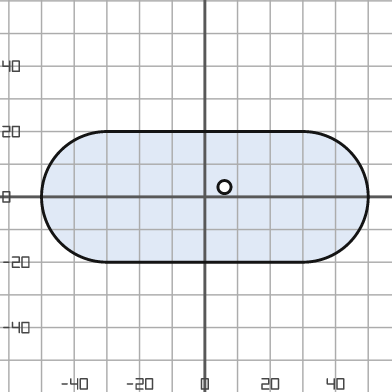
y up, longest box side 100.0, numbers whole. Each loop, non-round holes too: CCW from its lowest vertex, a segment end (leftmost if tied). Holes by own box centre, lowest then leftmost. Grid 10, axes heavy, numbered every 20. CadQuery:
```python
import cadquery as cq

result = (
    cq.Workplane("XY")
    .moveTo(-30.0, -20.0)
    .lineTo(30.0, -20.0)
    .threePointArc((50.0, 0.0), (30.0, 20.0))
    .lineTo(-30.0, 20.0)
    .threePointArc((-50.0, 0.0), (-30.0, -20.0))
    .close()
    .moveTo(6.0, 3.0)
    .circle(2.0)
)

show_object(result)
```